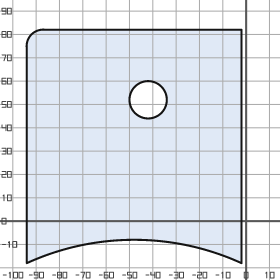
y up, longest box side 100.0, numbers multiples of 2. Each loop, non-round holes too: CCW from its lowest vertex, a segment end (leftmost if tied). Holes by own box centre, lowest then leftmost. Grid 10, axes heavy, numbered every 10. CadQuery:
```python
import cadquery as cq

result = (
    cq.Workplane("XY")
    .moveTo(-94.0, -18.0)
    .threePointArc((-48.0, -8.0), (-2.0, -18.0))
    .lineTo(-2.0, 82.0)
    .lineTo(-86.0, 82.0)
    .threePointArc((-92.0, 80.0), (-94.0, 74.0))
    .close()
    .moveTo(-42.0, 52.0)
    .circle(8.0)
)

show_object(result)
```